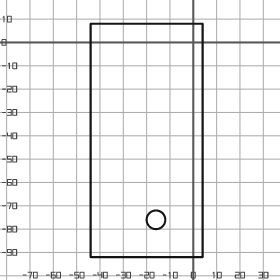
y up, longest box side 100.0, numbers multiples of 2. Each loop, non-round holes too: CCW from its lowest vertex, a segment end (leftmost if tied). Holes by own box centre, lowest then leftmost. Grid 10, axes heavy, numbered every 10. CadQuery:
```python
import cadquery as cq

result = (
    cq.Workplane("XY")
    .moveTo(-44.0, -92.0)
    .lineTo(4.0, -92.0)
    .lineTo(4.0, 8.0)
    .lineTo(-44.0, 8.0)
    .close()
    .moveTo(-16.0, -76.0)
    .circle(4.0)
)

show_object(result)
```